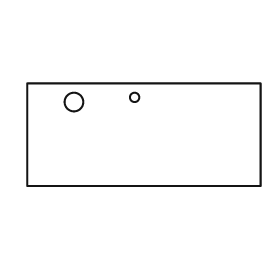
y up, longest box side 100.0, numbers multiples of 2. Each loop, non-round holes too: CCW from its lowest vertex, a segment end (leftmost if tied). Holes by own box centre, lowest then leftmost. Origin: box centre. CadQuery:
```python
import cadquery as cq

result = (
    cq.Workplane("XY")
    .moveTo(-50.0, -22.0)
    .lineTo(50.0, -22.0)
    .lineTo(50.0, 22.0)
    .lineTo(-50.0, 22.0)
    .close()
    .moveTo(-30.0, 14.0)
    .circle(4.0)
    .moveTo(-4.0, 16.0)
    .circle(2.0)
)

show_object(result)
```